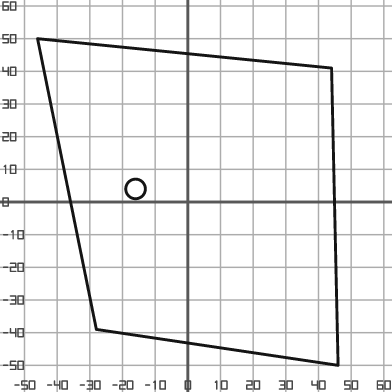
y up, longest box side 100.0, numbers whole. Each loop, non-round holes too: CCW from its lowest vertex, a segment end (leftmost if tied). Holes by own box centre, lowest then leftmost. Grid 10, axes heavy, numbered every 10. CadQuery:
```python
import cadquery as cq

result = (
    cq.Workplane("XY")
    .moveTo(46.0, -50.0)
    .lineTo(44.0, 41.0)
    .lineTo(-46.0, 50.0)
    .lineTo(-28.0, -39.0)
    .close()
    .moveTo(-16.0, 4.0)
    .circle(3.0)
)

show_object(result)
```